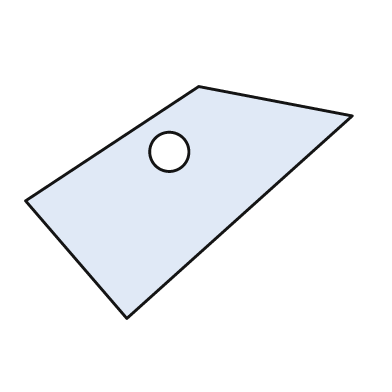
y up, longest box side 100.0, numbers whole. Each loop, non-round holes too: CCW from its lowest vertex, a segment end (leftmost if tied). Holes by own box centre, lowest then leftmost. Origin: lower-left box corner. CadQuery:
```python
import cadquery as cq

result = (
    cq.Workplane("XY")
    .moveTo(31.0, 0.0)
    .lineTo(100.0, 62.0)
    .lineTo(53.0, 71.0)
    .lineTo(0.0, 36.0)
    .close()
    .moveTo(44.0, 51.0)
    .circle(6.0)
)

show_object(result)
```